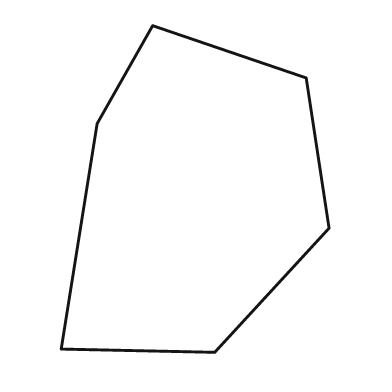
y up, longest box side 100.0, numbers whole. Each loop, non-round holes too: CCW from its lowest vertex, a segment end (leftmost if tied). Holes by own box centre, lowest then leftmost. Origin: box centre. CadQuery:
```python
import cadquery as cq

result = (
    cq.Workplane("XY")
    .moveTo(6.0, -50.0)
    .lineTo(41.0, -12.0)
    .lineTo(34.0, 34.0)
    .lineTo(-13.0, 50.0)
    .lineTo(-30.0, 20.0)
    .lineTo(-41.0, -49.0)
    .close()
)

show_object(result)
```